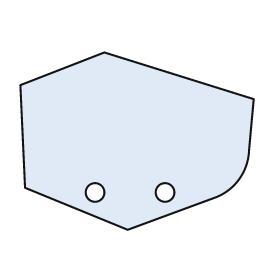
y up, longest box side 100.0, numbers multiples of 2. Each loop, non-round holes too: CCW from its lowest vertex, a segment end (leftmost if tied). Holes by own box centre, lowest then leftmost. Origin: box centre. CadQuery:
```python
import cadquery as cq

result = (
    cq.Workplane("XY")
    .moveTo(-4.0, -38.0)
    .lineTo(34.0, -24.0)
    .threePointArc((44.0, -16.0), (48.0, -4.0))
    .lineTo(50.0, 18.0)
    .lineTo(-14.0, 38.0)
    .lineTo(-50.0, 24.0)
    .lineTo(-48.0, -20.0)
    .close()
    .moveTo(-18.0, -22.0)
    .circle(4.0)
    .moveTo(12.0, -22.0)
    .circle(4.0)
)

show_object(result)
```